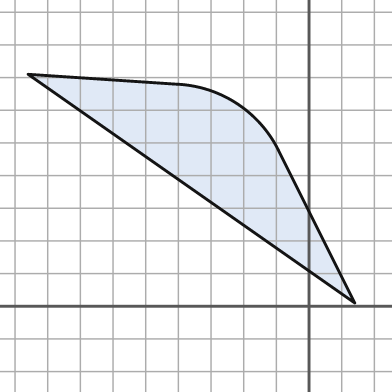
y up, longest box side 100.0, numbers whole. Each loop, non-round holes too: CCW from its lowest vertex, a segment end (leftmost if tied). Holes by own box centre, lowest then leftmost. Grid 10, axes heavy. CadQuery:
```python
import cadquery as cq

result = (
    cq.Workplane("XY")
    .moveTo(14.0, 1.0)
    .lineTo(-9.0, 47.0)
    .threePointArc((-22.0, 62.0), (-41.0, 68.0))
    .lineTo(-86.0, 71.0)
    .close()
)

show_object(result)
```